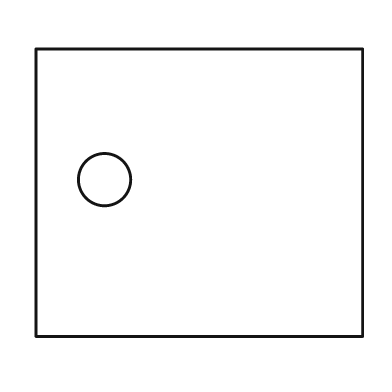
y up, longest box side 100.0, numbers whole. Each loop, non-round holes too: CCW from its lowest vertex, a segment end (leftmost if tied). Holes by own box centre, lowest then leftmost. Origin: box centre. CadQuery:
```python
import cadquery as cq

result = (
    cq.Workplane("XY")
    .moveTo(-50.0, -44.0)
    .lineTo(50.0, -44.0)
    .lineTo(50.0, 44.0)
    .lineTo(-50.0, 44.0)
    .close()
    .moveTo(-29.0, 4.0)
    .circle(8.0)
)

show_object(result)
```